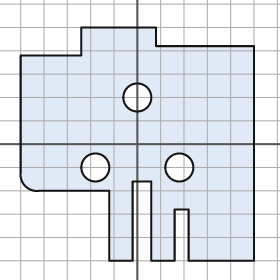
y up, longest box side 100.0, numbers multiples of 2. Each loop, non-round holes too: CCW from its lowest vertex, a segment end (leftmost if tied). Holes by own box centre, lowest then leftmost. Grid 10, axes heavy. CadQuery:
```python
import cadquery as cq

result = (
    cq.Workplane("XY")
    .moveTo(-12.0, -50.0)
    .lineTo(-2.0, -50.0)
    .lineTo(-2.0, -16.0)
    .lineTo(6.0, -16.0)
    .lineTo(6.0, -50.0)
    .lineTo(16.0, -50.0)
    .lineTo(16.0, -28.0)
    .lineTo(22.0, -28.0)
    .lineTo(22.0, -50.0)
    .lineTo(50.0, -50.0)
    .lineTo(50.0, 42.0)
    .lineTo(8.0, 42.0)
    .lineTo(8.0, 50.0)
    .lineTo(-24.0, 50.0)
    .lineTo(-24.0, 38.0)
    .lineTo(-50.0, 38.0)
    .lineTo(-50.0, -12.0)
    .threePointArc((-48.0, -18.0), (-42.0, -20.0))
    .lineTo(-12.0, -20.0)
    .close()
    .moveTo(-18.0, -10.0)
    .circle(6.0)
    .moveTo(18.0, -10.0)
    .circle(6.0)
    .moveTo(0.0, 20.0)
    .circle(6.0)
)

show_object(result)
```